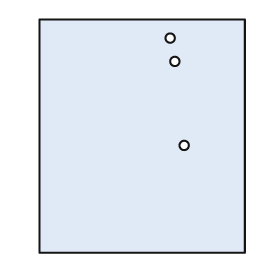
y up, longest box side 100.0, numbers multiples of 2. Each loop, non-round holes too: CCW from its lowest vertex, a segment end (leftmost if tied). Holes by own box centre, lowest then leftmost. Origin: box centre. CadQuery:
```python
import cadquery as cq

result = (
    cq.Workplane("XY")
    .moveTo(-44.0, -50.0)
    .lineTo(44.0, -50.0)
    .lineTo(44.0, 50.0)
    .lineTo(-44.0, 50.0)
    .close()
    .moveTo(18.0, -4.0)
    .circle(2.0)
    .moveTo(14.0, 32.0)
    .circle(2.0)
    .moveTo(12.0, 42.0)
    .circle(2.0)
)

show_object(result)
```